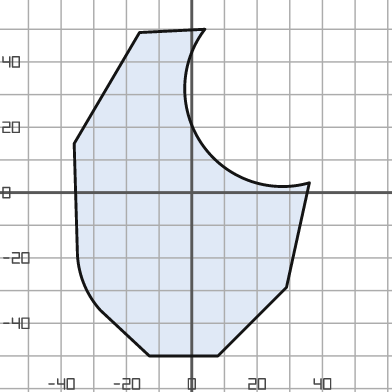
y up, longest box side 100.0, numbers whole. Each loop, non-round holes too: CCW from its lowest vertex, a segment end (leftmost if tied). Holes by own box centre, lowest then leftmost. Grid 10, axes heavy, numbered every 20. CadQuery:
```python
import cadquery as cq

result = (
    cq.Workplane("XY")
    .moveTo(-13.0, -50.0)
    .lineTo(8.0, -50.0)
    .lineTo(29.0, -29.0)
    .lineTo(36.0, 3.0)
    .threePointArc((3.0, 15.0), (4.0, 50.0))
    .lineTo(-16.0, 49.0)
    .lineTo(-36.0, 15.0)
    .lineTo(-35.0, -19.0)
    .threePointArc((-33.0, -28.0), (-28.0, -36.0))
    .close()
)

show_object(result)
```